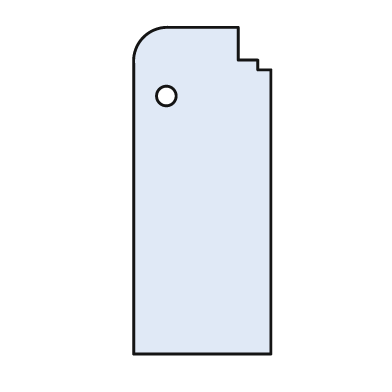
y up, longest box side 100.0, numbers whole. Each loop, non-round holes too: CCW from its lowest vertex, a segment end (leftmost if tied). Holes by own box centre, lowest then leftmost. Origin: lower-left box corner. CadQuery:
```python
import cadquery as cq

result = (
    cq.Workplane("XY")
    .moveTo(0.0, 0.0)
    .lineTo(42.0, 0.0)
    .lineTo(42.0, 87.0)
    .lineTo(38.0, 87.0)
    .lineTo(38.0, 90.0)
    .lineTo(32.0, 90.0)
    .lineTo(32.0, 100.0)
    .lineTo(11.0, 100.0)
    .threePointArc((3.0, 97.0), (0.0, 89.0))
    .close()
    .moveTo(10.0, 79.0)
    .circle(3.0)
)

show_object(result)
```